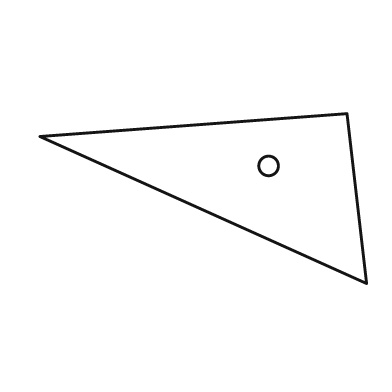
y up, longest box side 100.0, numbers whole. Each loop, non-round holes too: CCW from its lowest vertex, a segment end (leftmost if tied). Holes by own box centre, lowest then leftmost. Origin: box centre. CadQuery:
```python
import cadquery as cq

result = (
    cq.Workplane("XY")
    .moveTo(50.0, -26.0)
    .lineTo(44.0, 26.0)
    .lineTo(-50.0, 19.0)
    .close()
    .moveTo(20.0, 10.0)
    .circle(3.0)
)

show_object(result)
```